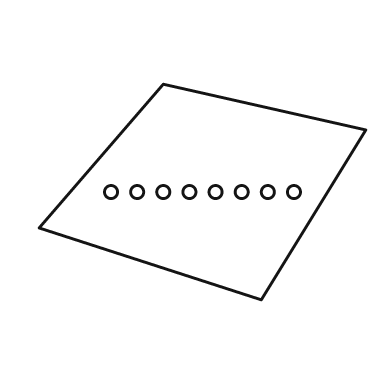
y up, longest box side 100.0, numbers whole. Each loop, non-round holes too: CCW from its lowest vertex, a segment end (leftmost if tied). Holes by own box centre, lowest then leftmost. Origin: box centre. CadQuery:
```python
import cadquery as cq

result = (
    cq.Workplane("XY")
    .moveTo(18.0, -33.0)
    .lineTo(50.0, 19.0)
    .lineTo(-12.0, 33.0)
    .lineTo(-50.0, -11.0)
    .close()
    .moveTo(-28.0, 0.0)
    .circle(2.0)
    .moveTo(-20.0, 0.0)
    .circle(2.0)
    .moveTo(-12.0, 0.0)
    .circle(2.0)
    .moveTo(-4.0, 0.0)
    .circle(2.0)
    .moveTo(4.0, 0.0)
    .circle(2.0)
    .moveTo(12.0, 0.0)
    .circle(2.0)
    .moveTo(20.0, 0.0)
    .circle(2.0)
    .moveTo(28.0, 0.0)
    .circle(2.0)
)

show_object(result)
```